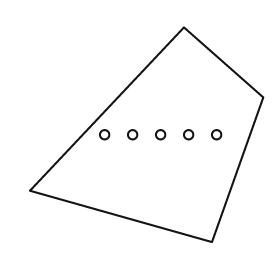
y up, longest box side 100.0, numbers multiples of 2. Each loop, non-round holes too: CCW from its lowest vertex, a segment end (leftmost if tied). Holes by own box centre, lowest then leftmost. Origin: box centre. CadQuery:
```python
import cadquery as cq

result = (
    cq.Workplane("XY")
    .moveTo(28.0, -46.0)
    .lineTo(50.0, 16.0)
    .lineTo(16.0, 46.0)
    .lineTo(-50.0, -24.0)
    .close()
    .moveTo(-18.0, 0.0)
    .circle(2.0)
    .moveTo(-6.0, 0.0)
    .circle(2.0)
    .moveTo(6.0, 0.0)
    .circle(2.0)
    .moveTo(18.0, 0.0)
    .circle(2.0)
    .moveTo(30.0, 0.0)
    .circle(2.0)
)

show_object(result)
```